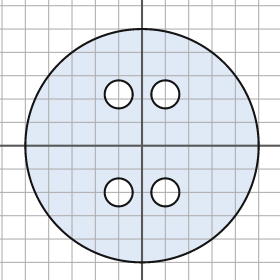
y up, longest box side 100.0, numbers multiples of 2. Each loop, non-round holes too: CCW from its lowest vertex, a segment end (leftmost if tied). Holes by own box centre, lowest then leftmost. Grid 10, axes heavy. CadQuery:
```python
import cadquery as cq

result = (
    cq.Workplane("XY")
    .moveTo(0.0, 0.0)
    .circle(50.0)
    .moveTo(-10.0, -20.0)
    .circle(6.0)
    .moveTo(10.0, -20.0)
    .circle(6.0)
    .moveTo(-10.0, 22.0)
    .circle(6.0)
    .moveTo(10.0, 22.0)
    .circle(6.0)
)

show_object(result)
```